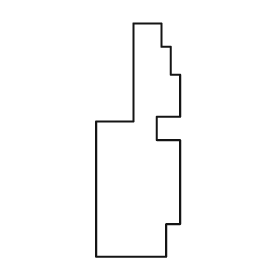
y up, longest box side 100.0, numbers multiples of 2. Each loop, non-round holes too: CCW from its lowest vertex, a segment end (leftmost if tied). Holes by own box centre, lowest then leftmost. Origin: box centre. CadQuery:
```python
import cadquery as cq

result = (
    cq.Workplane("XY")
    .moveTo(-18.0, -50.0)
    .lineTo(12.0, -50.0)
    .lineTo(12.0, -36.0)
    .lineTo(18.0, -36.0)
    .lineTo(18.0, 0.0)
    .lineTo(8.0, 0.0)
    .lineTo(8.0, 10.0)
    .lineTo(18.0, 10.0)
    .lineTo(18.0, 28.0)
    .lineTo(14.0, 28.0)
    .lineTo(14.0, 40.0)
    .lineTo(10.0, 40.0)
    .lineTo(10.0, 50.0)
    .lineTo(-2.0, 50.0)
    .lineTo(-2.0, 8.0)
    .lineTo(-18.0, 8.0)
    .close()
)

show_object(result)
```